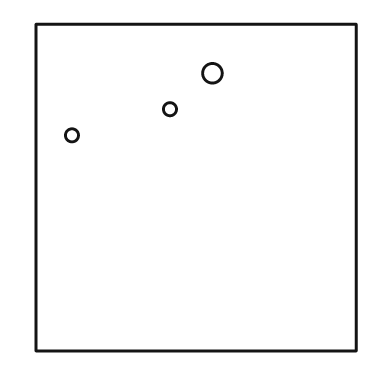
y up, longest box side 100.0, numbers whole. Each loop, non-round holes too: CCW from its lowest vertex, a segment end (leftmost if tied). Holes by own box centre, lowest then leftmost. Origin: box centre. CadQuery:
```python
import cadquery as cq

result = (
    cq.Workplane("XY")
    .moveTo(-49.0, -50.0)
    .lineTo(49.0, -50.0)
    .lineTo(49.0, 50.0)
    .lineTo(-49.0, 50.0)
    .close()
    .moveTo(-38.0, 16.0)
    .circle(2.0)
    .moveTo(-8.0, 24.0)
    .circle(2.0)
    .moveTo(5.0, 35.0)
    .circle(3.0)
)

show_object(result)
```